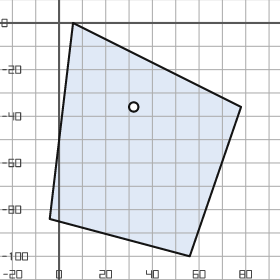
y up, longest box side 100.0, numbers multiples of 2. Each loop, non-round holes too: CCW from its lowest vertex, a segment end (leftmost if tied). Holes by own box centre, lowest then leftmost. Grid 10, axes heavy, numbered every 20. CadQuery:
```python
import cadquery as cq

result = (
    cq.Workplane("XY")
    .moveTo(56.0, -100.0)
    .lineTo(78.0, -36.0)
    .lineTo(6.0, 0.0)
    .lineTo(-4.0, -84.0)
    .close()
    .moveTo(32.0, -36.0)
    .circle(2.0)
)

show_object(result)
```